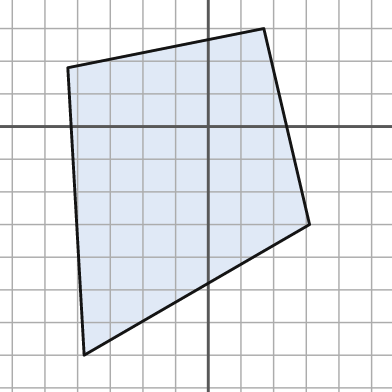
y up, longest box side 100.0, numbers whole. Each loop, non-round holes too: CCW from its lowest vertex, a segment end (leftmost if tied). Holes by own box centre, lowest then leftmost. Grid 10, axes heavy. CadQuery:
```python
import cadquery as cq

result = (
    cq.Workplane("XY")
    .moveTo(-38.0, -70.0)
    .lineTo(31.0, -30.0)
    .lineTo(17.0, 30.0)
    .lineTo(-43.0, 18.0)
    .close()
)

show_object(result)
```